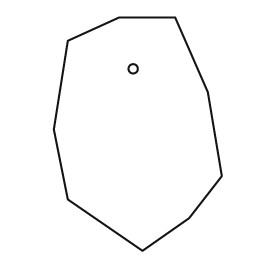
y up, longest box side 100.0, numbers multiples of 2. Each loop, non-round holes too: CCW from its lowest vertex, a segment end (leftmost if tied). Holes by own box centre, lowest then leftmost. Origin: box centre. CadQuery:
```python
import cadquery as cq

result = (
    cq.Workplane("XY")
    .moveTo(2.0, -50.0)
    .lineTo(22.0, -36.0)
    .lineTo(36.0, -18.0)
    .lineTo(30.0, 18.0)
    .lineTo(16.0, 50.0)
    .lineTo(-8.0, 50.0)
    .lineTo(-30.0, 40.0)
    .lineTo(-36.0, 2.0)
    .lineTo(-30.0, -28.0)
    .close()
    .moveTo(-2.0, 28.0)
    .circle(2.0)
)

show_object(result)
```